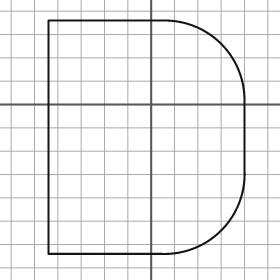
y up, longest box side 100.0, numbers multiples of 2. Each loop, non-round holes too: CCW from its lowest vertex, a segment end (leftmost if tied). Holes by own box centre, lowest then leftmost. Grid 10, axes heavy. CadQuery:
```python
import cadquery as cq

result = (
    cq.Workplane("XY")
    .moveTo(-44.0, -64.0)
    .lineTo(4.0, -64.0)
    .threePointArc((30.0, -54.0), (40.0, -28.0))
    .lineTo(40.0, 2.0)
    .threePointArc((30.0, 26.0), (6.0, 36.0))
    .lineTo(-44.0, 36.0)
    .close()
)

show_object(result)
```